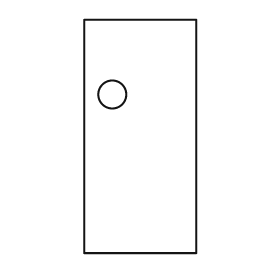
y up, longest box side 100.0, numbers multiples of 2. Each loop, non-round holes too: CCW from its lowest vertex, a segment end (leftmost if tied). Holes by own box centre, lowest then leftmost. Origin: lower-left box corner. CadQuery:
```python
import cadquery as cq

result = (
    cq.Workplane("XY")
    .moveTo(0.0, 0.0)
    .lineTo(48.0, 0.0)
    .lineTo(48.0, 100.0)
    .lineTo(0.0, 100.0)
    .close()
    .moveTo(12.0, 68.0)
    .circle(6.0)
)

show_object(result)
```